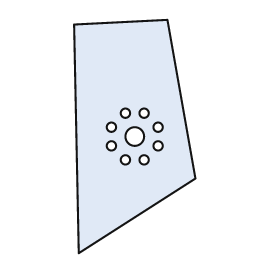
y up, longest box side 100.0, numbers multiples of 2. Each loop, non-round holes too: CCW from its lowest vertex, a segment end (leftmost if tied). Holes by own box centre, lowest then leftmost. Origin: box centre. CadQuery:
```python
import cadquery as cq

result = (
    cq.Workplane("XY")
    .moveTo(-24.0, -50.0)
    .lineTo(26.0, -18.0)
    .lineTo(14.0, 50.0)
    .lineTo(-26.0, 48.0)
    .close()
    .moveTo(-4.0, -10.0)
    .circle(2.0)
    .moveTo(4.0, -10.0)
    .circle(2.0)
    .moveTo(-10.0, -4.0)
    .circle(2.0)
    .moveTo(10.0, -4.0)
    .circle(2.0)
    .moveTo(0.0, 0.0)
    .circle(4.0)
    .moveTo(-10.0, 4.0)
    .circle(2.0)
    .moveTo(10.0, 4.0)
    .circle(2.0)
    .moveTo(-4.0, 10.0)
    .circle(2.0)
    .moveTo(4.0, 10.0)
    .circle(2.0)
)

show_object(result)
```